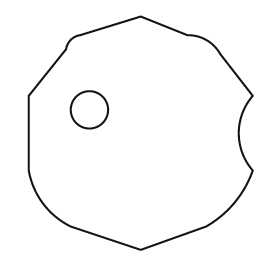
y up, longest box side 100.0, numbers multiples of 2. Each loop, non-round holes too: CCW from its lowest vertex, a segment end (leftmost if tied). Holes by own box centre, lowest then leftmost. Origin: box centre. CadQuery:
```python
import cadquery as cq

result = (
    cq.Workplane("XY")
    .moveTo(0.0, -50.0)
    .lineTo(28.0, -40.0)
    .threePointArc((40.0, -30.0), (48.0, -16.0))
    .threePointArc((42.0, 0.0), (48.0, 16.0))
    .lineTo(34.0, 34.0)
    .threePointArc((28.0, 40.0), (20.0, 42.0))
    .lineTo(0.0, 50.0)
    .lineTo(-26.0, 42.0)
    .threePointArc((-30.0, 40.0), (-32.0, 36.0))
    .lineTo(-48.0, 16.0)
    .lineTo(-48.0, -16.0)
    .threePointArc((-42.0, -30.0), (-30.0, -40.0))
    .close()
    .moveTo(-22.0, 10.0)
    .circle(8.0)
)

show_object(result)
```